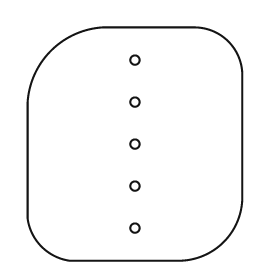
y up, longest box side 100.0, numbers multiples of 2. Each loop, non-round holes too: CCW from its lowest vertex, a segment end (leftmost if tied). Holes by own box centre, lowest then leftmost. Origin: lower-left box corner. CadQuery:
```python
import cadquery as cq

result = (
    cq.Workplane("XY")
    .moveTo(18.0, 0.0)
    .lineTo(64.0, 0.0)
    .threePointArc((84.0, 8.0), (92.0, 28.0))
    .lineTo(92.0, 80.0)
    .threePointArc((86.0, 94.0), (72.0, 100.0))
    .lineTo(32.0, 100.0)
    .threePointArc((10.0, 90.0), (0.0, 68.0))
    .lineTo(0.0, 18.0)
    .threePointArc((6.0, 6.0), (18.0, 0.0))
    .close()
    .moveTo(46.0, 14.0)
    .circle(2.0)
    .moveTo(46.0, 32.0)
    .circle(2.0)
    .moveTo(46.0, 50.0)
    .circle(2.0)
    .moveTo(46.0, 68.0)
    .circle(2.0)
    .moveTo(46.0, 86.0)
    .circle(2.0)
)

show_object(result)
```